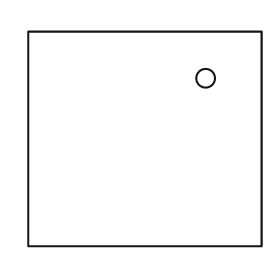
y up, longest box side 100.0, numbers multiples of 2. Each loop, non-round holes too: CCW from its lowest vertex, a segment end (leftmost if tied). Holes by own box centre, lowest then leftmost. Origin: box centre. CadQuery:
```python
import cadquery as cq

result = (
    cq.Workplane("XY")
    .moveTo(-50.0, -46.0)
    .lineTo(50.0, -46.0)
    .lineTo(50.0, 46.0)
    .lineTo(-50.0, 46.0)
    .close()
    .moveTo(26.0, 26.0)
    .circle(4.0)
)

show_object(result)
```